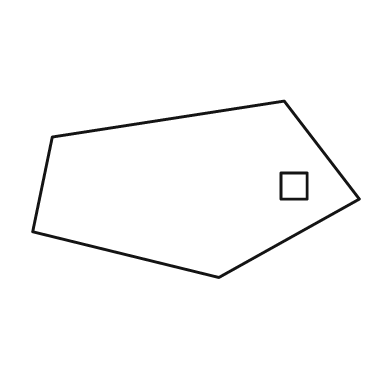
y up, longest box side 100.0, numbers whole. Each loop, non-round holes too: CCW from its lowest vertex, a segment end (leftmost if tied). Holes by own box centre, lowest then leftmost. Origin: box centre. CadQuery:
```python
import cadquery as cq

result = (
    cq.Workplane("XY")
    .moveTo(7.0, -27.0)
    .lineTo(50.0, -3.0)
    .lineTo(27.0, 27.0)
    .lineTo(-44.0, 16.0)
    .lineTo(-50.0, -13.0)
    .close()
    .moveTo(26.0, -3.0)
    .lineTo(34.0, -3.0)
    .lineTo(34.0, 5.0)
    .lineTo(26.0, 5.0)
    .close()
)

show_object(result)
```